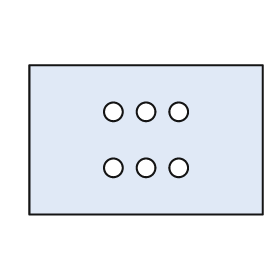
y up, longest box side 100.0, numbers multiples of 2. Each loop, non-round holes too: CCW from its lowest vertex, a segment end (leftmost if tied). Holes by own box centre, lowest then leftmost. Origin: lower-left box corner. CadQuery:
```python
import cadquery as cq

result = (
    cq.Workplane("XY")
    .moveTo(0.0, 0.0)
    .lineTo(100.0, 0.0)
    .lineTo(100.0, 64.0)
    .lineTo(0.0, 64.0)
    .close()
    .moveTo(36.0, 20.0)
    .circle(4.0)
    .moveTo(50.0, 20.0)
    .circle(4.0)
    .moveTo(64.0, 20.0)
    .circle(4.0)
    .moveTo(36.0, 44.0)
    .circle(4.0)
    .moveTo(50.0, 44.0)
    .circle(4.0)
    .moveTo(64.0, 44.0)
    .circle(4.0)
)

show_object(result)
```